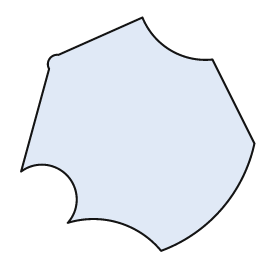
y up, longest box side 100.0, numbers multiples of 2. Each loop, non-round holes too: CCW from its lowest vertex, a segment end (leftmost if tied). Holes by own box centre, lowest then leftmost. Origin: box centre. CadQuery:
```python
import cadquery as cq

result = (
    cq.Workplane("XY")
    .moveTo(10.0, -50.0)
    .threePointArc((36.0, -32.0), (50.0, -4.0))
    .lineTo(32.0, 32.0)
    .threePointArc((14.0, 36.0), (2.0, 50.0))
    .lineTo(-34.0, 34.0)
    .threePointArc((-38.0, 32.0), (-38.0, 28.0))
    .lineTo(-50.0, -16.0)
    .threePointArc((-30.0, -18.0), (-30.0, -38.0))
    .threePointArc((-8.0, -38.0), (10.0, -50.0))
    .close()
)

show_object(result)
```